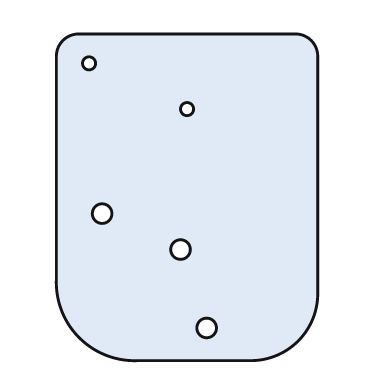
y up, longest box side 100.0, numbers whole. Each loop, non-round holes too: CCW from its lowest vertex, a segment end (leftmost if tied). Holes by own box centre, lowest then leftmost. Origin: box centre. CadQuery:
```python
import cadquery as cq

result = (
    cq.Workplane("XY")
    .moveTo(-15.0, -50.0)
    .lineTo(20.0, -50.0)
    .threePointArc((34.0, -44.0), (40.0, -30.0))
    .lineTo(40.0, 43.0)
    .threePointArc((38.0, 48.0), (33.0, 50.0))
    .lineTo(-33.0, 50.0)
    .threePointArc((-38.0, 48.0), (-40.0, 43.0))
    .lineTo(-40.0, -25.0)
    .threePointArc((-33.0, -43.0), (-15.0, -50.0))
    .close()
    .moveTo(6.0, -40.0)
    .circle(3.0)
    .moveTo(-2.0, -16.0)
    .circle(3.0)
    .moveTo(-26.0, -5.0)
    .circle(3.0)
    .moveTo(0.0, 27.0)
    .circle(2.0)
    .moveTo(-30.0, 41.0)
    .circle(2.0)
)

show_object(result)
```